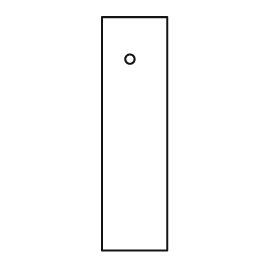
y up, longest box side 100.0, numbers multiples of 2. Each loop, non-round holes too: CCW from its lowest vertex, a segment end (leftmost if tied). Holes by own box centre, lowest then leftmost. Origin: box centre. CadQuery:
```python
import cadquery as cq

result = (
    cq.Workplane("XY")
    .moveTo(-14.0, -50.0)
    .lineTo(14.0, -50.0)
    .lineTo(14.0, 50.0)
    .lineTo(-14.0, 50.0)
    .close()
    .moveTo(-2.0, 32.0)
    .circle(2.0)
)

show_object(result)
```